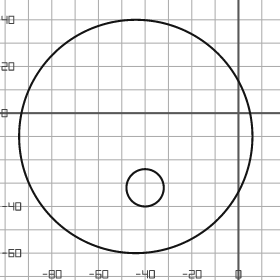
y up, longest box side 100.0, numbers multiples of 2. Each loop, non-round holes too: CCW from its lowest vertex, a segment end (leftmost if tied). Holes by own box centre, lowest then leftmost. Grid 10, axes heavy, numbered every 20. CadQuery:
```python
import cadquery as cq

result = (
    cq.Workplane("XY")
    .moveTo(-44.0, -10.0)
    .circle(50.0)
    .moveTo(-40.0, -32.0)
    .circle(8.0)
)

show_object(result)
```